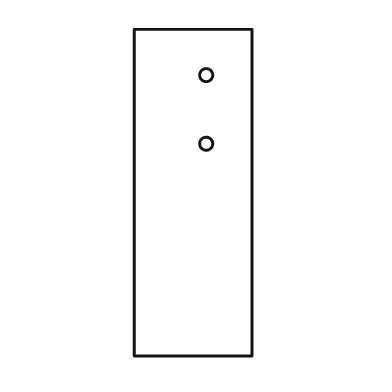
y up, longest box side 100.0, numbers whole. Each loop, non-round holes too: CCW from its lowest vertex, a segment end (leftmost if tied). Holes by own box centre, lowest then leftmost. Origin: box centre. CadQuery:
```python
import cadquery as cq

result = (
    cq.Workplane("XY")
    .moveTo(-18.0, -50.0)
    .lineTo(18.0, -50.0)
    .lineTo(18.0, 50.0)
    .lineTo(-18.0, 50.0)
    .close()
    .moveTo(4.0, 15.0)
    .circle(2.0)
    .moveTo(4.0, 36.0)
    .circle(2.0)
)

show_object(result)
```